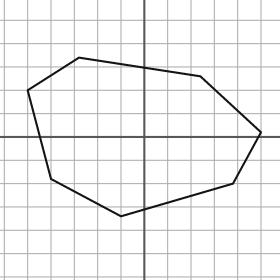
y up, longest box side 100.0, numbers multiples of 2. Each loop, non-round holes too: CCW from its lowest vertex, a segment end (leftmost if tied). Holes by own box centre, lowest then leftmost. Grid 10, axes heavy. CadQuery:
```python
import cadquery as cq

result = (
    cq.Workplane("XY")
    .moveTo(-10.0, -34.0)
    .lineTo(38.0, -20.0)
    .lineTo(50.0, 2.0)
    .lineTo(24.0, 26.0)
    .lineTo(-28.0, 34.0)
    .lineTo(-50.0, 20.0)
    .lineTo(-40.0, -18.0)
    .close()
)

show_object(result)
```